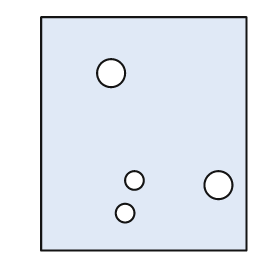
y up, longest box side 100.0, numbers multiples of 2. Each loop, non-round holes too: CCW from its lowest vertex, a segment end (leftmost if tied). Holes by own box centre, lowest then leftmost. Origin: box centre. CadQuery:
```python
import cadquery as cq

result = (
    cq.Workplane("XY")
    .moveTo(-44.0, -50.0)
    .lineTo(44.0, -50.0)
    .lineTo(44.0, 50.0)
    .lineTo(-44.0, 50.0)
    .close()
    .moveTo(-8.0, -34.0)
    .circle(4.0)
    .moveTo(32.0, -22.0)
    .circle(6.0)
    .moveTo(-4.0, -20.0)
    .circle(4.0)
    .moveTo(-14.0, 26.0)
    .circle(6.0)
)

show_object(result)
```